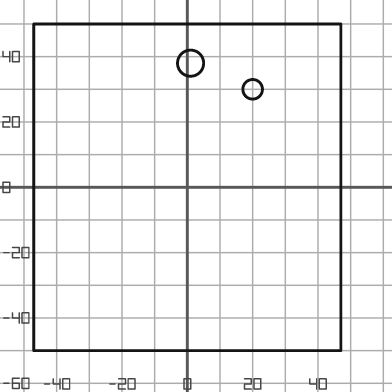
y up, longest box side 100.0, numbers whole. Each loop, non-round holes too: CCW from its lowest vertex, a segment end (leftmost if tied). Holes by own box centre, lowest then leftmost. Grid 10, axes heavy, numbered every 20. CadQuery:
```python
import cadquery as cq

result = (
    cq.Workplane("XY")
    .moveTo(-47.0, -50.0)
    .lineTo(47.0, -50.0)
    .lineTo(47.0, 50.0)
    .lineTo(-47.0, 50.0)
    .close()
    .moveTo(20.0, 30.0)
    .circle(3.0)
    .moveTo(1.0, 38.0)
    .circle(4.0)
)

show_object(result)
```